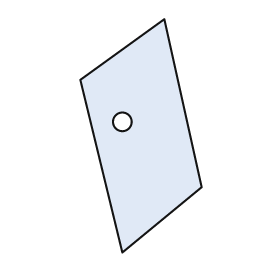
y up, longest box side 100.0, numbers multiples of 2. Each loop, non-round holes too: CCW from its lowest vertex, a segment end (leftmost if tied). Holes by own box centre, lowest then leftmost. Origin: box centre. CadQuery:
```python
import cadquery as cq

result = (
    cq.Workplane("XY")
    .moveTo(-8.0, -50.0)
    .lineTo(26.0, -22.0)
    .lineTo(10.0, 50.0)
    .lineTo(-26.0, 24.0)
    .close()
    .moveTo(-8.0, 6.0)
    .circle(4.0)
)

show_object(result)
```